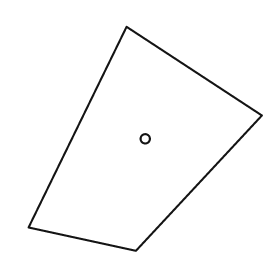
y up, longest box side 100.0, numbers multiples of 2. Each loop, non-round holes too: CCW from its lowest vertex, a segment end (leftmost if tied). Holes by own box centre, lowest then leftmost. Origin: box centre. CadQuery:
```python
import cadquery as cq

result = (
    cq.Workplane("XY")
    .moveTo(-4.0, -48.0)
    .lineTo(50.0, 10.0)
    .lineTo(-8.0, 48.0)
    .lineTo(-50.0, -38.0)
    .close()
    .moveTo(0.0, 0.0)
    .circle(2.0)
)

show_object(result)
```